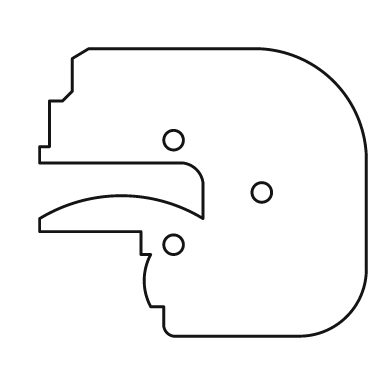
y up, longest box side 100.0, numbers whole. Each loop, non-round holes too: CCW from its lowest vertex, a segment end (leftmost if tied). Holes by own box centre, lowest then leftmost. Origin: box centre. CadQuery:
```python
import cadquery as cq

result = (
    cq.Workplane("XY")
    .moveTo(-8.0, -44.0)
    .lineTo(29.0, -44.0)
    .threePointArc((44.0, -38.0), (50.0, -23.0))
    .lineTo(50.0, 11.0)
    .threePointArc((40.0, 34.0), (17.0, 44.0))
    .lineTo(-35.0, 44.0)
    .lineTo(-40.0, 41.0)
    .lineTo(-40.0, 31.0)
    .lineTo(-43.0, 28.0)
    .lineTo(-47.0, 28.0)
    .lineTo(-47.0, 14.0)
    .lineTo(-50.0, 14.0)
    .lineTo(-50.0, 9.0)
    .lineTo(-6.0, 9.0)
    .threePointArc((-2.0, 7.0), (0.0, 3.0))
    .lineTo(0.0, -8.0)
    .threePointArc((-25.0, -1.0), (-50.0, -8.0))
    .lineTo(-50.0, -12.0)
    .lineTo(-19.0, -12.0)
    .lineTo(-19.0, -19.0)
    .lineTo(-16.0, -19.0)
    .threePointArc((-18.0, -27.0), (-16.0, -35.0))
    .lineTo(-12.0, -35.0)
    .lineTo(-12.0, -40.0)
    .threePointArc((-11.0, -43.0), (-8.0, -44.0))
    .close()
    .moveTo(-9.0, -16.0)
    .circle(3.0)
    .moveTo(18.0, 0.0)
    .circle(3.0)
    .moveTo(-9.0, 16.0)
    .circle(3.0)
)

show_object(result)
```